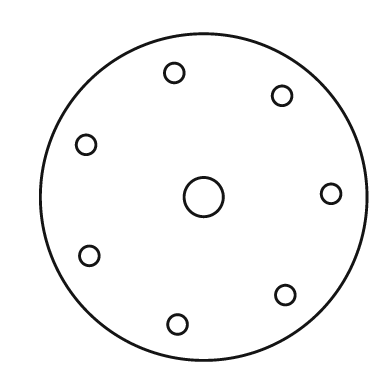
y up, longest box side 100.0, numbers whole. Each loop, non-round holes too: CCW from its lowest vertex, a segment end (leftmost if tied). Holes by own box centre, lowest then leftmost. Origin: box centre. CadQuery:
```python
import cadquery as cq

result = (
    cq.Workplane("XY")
    .moveTo(0.0, 0.0)
    .circle(50.0)
    .moveTo(-8.0, -39.0)
    .circle(3.0)
    .moveTo(25.0, -30.0)
    .circle(3.0)
    .moveTo(-35.0, -18.0)
    .circle(3.0)
    .moveTo(0.0, 0.0)
    .circle(6.0)
    .moveTo(39.0, 1.0)
    .circle(3.0)
    .moveTo(-36.0, 16.0)
    .circle(3.0)
    .moveTo(24.0, 31.0)
    .circle(3.0)
    .moveTo(-9.0, 38.0)
    .circle(3.0)
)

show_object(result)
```